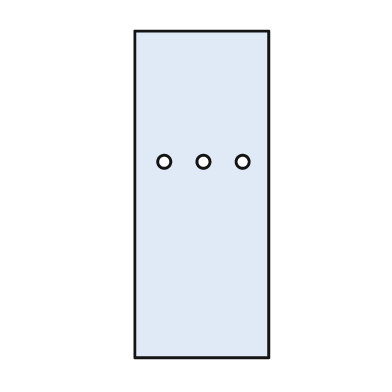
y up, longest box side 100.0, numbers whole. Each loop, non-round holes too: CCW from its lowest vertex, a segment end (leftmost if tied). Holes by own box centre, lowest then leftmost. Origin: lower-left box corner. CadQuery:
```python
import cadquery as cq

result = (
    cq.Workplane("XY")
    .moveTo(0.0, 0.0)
    .lineTo(41.0, 0.0)
    .lineTo(41.0, 100.0)
    .lineTo(0.0, 100.0)
    .close()
    .moveTo(9.0, 60.0)
    .circle(2.0)
    .moveTo(21.0, 60.0)
    .circle(2.0)
    .moveTo(33.0, 60.0)
    .circle(2.0)
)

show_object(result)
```